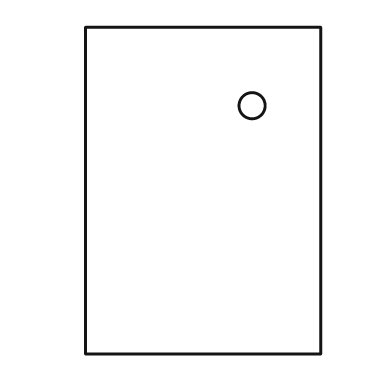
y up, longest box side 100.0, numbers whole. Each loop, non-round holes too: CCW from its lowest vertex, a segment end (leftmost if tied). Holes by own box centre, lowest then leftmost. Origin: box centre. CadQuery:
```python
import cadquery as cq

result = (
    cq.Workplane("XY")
    .moveTo(-36.0, -50.0)
    .lineTo(36.0, -50.0)
    .lineTo(36.0, 50.0)
    .lineTo(-36.0, 50.0)
    .close()
    .moveTo(15.0, 26.0)
    .circle(4.0)
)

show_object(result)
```